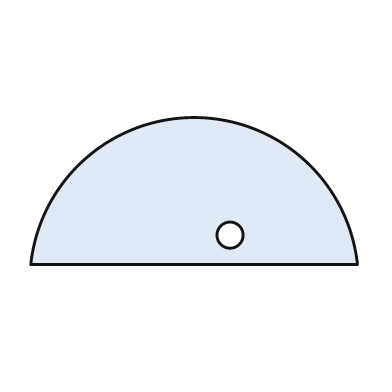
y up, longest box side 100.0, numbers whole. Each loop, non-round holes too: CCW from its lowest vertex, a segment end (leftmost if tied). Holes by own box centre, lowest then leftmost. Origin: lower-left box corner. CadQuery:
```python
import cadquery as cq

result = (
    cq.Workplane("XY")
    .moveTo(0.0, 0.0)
    .lineTo(100.0, 0.0)
    .threePointArc((50.0, 45.0), (0.0, 0.0))
    .close()
    .moveTo(61.0, 9.0)
    .circle(4.0)
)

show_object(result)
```